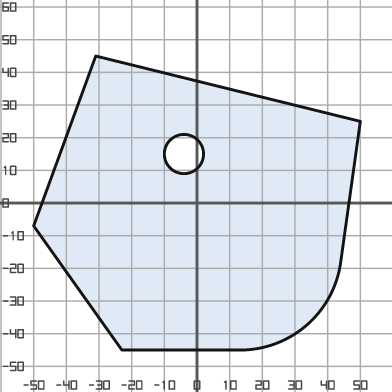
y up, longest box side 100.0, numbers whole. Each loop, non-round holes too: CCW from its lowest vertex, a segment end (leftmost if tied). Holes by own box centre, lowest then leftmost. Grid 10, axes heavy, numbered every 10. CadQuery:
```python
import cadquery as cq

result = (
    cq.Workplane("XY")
    .moveTo(-23.0, -45.0)
    .lineTo(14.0, -45.0)
    .threePointArc((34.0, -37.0), (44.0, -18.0))
    .lineTo(50.0, 25.0)
    .lineTo(-31.0, 45.0)
    .lineTo(-50.0, -7.0)
    .close()
    .moveTo(-4.0, 15.0)
    .circle(6.0)
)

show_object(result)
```